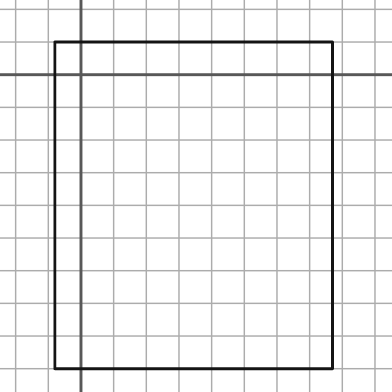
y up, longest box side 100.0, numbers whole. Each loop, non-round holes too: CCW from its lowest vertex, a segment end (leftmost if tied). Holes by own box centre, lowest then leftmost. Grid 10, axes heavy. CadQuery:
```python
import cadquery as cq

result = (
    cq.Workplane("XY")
    .moveTo(-8.0, -90.0)
    .lineTo(77.0, -90.0)
    .lineTo(77.0, 10.0)
    .lineTo(-8.0, 10.0)
    .close()
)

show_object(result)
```